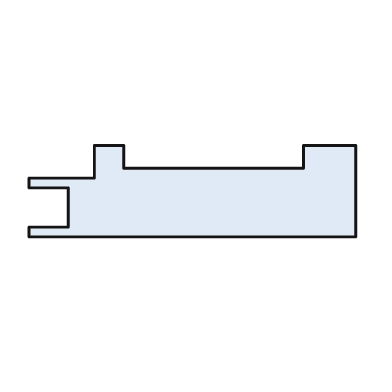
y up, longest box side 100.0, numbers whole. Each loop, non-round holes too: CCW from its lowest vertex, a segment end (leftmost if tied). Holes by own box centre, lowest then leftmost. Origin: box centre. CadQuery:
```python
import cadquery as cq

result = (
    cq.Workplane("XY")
    .moveTo(-50.0, -14.0)
    .lineTo(50.0, -14.0)
    .lineTo(50.0, 14.0)
    .lineTo(34.0, 14.0)
    .lineTo(34.0, 7.0)
    .lineTo(-21.0, 7.0)
    .lineTo(-21.0, 14.0)
    .lineTo(-30.0, 14.0)
    .lineTo(-30.0, 4.0)
    .lineTo(-50.0, 4.0)
    .lineTo(-50.0, 1.0)
    .lineTo(-38.0, 1.0)
    .lineTo(-38.0, -11.0)
    .lineTo(-50.0, -11.0)
    .close()
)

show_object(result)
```